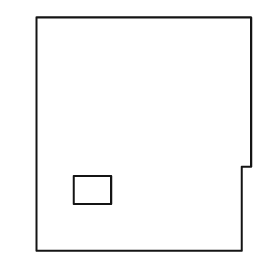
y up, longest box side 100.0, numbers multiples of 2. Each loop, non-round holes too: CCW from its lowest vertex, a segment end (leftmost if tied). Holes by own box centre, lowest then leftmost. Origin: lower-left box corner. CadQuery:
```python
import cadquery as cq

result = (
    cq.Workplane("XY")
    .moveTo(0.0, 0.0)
    .lineTo(88.0, 0.0)
    .lineTo(88.0, 36.0)
    .lineTo(92.0, 36.0)
    .lineTo(92.0, 100.0)
    .lineTo(0.0, 100.0)
    .close()
    .moveTo(16.0, 20.0)
    .lineTo(32.0, 20.0)
    .lineTo(32.0, 32.0)
    .lineTo(16.0, 32.0)
    .close()
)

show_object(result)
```